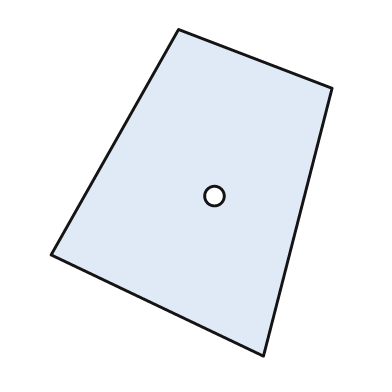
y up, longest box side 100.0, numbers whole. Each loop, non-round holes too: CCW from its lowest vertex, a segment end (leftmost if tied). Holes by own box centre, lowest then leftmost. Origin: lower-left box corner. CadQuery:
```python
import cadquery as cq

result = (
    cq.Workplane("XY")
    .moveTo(65.0, 0.0)
    .lineTo(86.0, 82.0)
    .lineTo(39.0, 100.0)
    .lineTo(0.0, 31.0)
    .close()
    .moveTo(50.0, 49.0)
    .circle(3.0)
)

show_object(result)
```